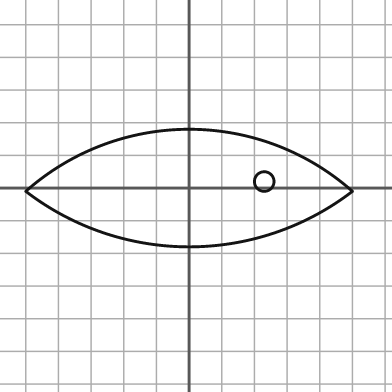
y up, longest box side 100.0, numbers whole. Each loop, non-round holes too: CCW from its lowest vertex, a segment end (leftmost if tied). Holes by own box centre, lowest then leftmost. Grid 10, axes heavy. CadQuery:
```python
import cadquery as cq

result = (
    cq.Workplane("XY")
    .moveTo(-50.0, -1.0)
    .threePointArc((0.0, -18.0), (50.0, -1.0))
    .threePointArc((0.0, 18.0), (-50.0, -1.0))
    .close()
    .moveTo(23.0, 2.0)
    .circle(3.0)
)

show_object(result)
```